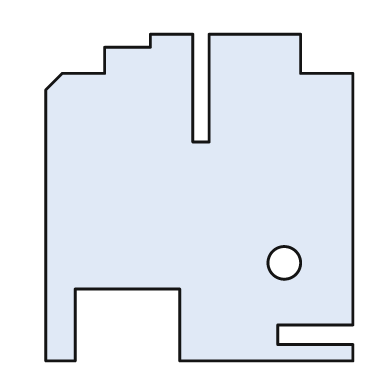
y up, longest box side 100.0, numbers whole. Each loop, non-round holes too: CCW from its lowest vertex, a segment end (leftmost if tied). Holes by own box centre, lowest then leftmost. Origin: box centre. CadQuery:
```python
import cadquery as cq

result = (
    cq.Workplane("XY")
    .moveTo(-47.0, -50.0)
    .lineTo(-38.0, -50.0)
    .lineTo(-38.0, -28.0)
    .lineTo(-6.0, -28.0)
    .lineTo(-6.0, -50.0)
    .lineTo(47.0, -50.0)
    .lineTo(47.0, -45.0)
    .lineTo(24.0, -45.0)
    .lineTo(24.0, -39.0)
    .lineTo(47.0, -39.0)
    .lineTo(47.0, 38.0)
    .lineTo(31.0, 38.0)
    .lineTo(31.0, 50.0)
    .lineTo(3.0, 50.0)
    .lineTo(3.0, 17.0)
    .lineTo(-2.0, 17.0)
    .lineTo(-2.0, 50.0)
    .lineTo(-15.0, 50.0)
    .lineTo(-15.0, 46.0)
    .lineTo(-29.0, 46.0)
    .lineTo(-29.0, 38.0)
    .lineTo(-42.0, 38.0)
    .lineTo(-47.0, 33.0)
    .close()
    .moveTo(26.0, -20.0)
    .circle(5.0)
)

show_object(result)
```